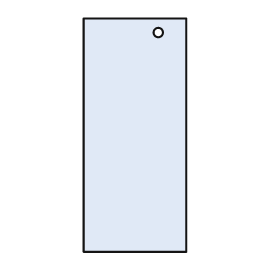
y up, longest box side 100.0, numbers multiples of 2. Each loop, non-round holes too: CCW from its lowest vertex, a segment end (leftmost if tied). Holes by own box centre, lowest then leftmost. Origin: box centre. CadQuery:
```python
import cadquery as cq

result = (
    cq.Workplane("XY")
    .moveTo(-22.0, -50.0)
    .lineTo(22.0, -50.0)
    .lineTo(22.0, 50.0)
    .lineTo(-22.0, 50.0)
    .close()
    .moveTo(10.0, 44.0)
    .circle(2.0)
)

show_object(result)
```